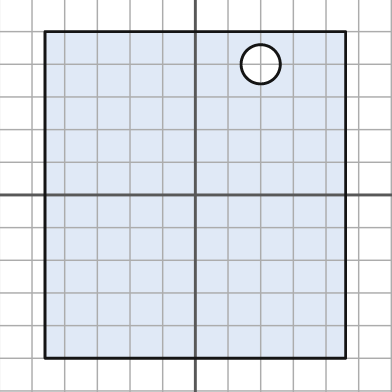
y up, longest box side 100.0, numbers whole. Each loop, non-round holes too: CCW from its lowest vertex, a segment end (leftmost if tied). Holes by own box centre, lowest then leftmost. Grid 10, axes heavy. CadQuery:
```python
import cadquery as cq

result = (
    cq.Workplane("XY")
    .moveTo(-46.0, -50.0)
    .lineTo(46.0, -50.0)
    .lineTo(46.0, 50.0)
    .lineTo(-46.0, 50.0)
    .close()
    .moveTo(20.0, 40.0)
    .circle(6.0)
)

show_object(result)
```